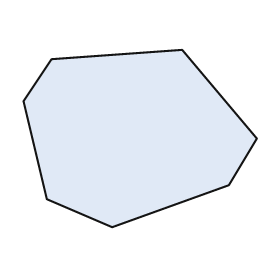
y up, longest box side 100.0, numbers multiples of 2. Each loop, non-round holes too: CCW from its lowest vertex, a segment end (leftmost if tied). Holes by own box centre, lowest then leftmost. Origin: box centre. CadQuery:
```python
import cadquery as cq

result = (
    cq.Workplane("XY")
    .moveTo(-12.0, -38.0)
    .lineTo(38.0, -20.0)
    .lineTo(50.0, 0.0)
    .lineTo(18.0, 38.0)
    .lineTo(-38.0, 34.0)
    .lineTo(-50.0, 16.0)
    .lineTo(-40.0, -26.0)
    .close()
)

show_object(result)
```